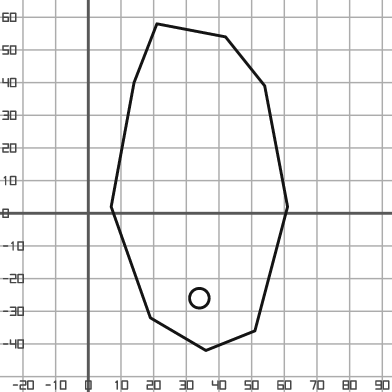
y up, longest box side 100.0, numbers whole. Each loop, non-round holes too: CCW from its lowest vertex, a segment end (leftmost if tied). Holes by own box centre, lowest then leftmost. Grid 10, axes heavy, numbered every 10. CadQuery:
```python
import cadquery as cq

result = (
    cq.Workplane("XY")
    .moveTo(36.0, -42.0)
    .lineTo(51.0, -36.0)
    .lineTo(61.0, 2.0)
    .lineTo(54.0, 39.0)
    .lineTo(42.0, 54.0)
    .lineTo(21.0, 58.0)
    .lineTo(14.0, 40.0)
    .lineTo(7.0, 2.0)
    .lineTo(19.0, -32.0)
    .close()
    .moveTo(34.0, -26.0)
    .circle(3.0)
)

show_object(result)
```